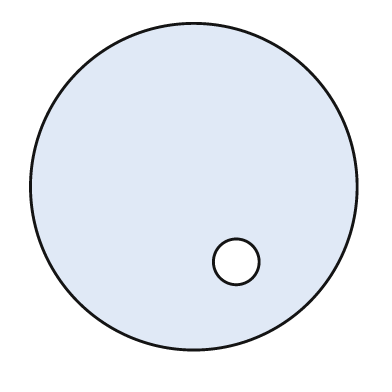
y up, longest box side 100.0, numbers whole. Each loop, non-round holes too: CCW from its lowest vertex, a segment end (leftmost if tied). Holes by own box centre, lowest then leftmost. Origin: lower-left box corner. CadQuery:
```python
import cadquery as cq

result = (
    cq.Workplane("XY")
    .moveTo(50.0, 50.0)
    .circle(50.0)
    .moveTo(63.0, 27.0)
    .circle(7.0)
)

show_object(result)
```